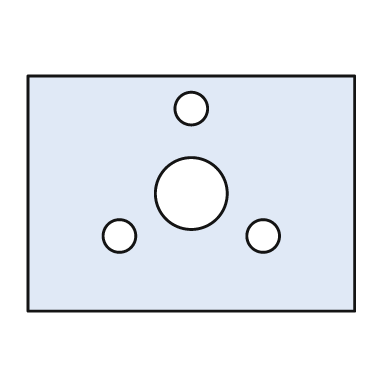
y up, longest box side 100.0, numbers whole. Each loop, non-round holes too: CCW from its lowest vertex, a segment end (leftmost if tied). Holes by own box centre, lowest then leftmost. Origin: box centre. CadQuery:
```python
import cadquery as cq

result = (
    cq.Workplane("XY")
    .moveTo(-50.0, -36.0)
    .lineTo(50.0, -36.0)
    .lineTo(50.0, 36.0)
    .lineTo(-50.0, 36.0)
    .close()
    .moveTo(-22.0, -13.0)
    .circle(5.0)
    .moveTo(22.0, -13.0)
    .circle(5.0)
    .moveTo(0.0, 0.0)
    .circle(11.0)
    .moveTo(0.0, 26.0)
    .circle(5.0)
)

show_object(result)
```